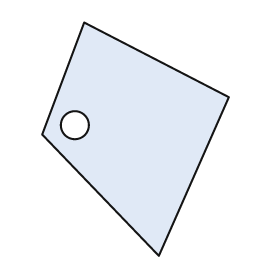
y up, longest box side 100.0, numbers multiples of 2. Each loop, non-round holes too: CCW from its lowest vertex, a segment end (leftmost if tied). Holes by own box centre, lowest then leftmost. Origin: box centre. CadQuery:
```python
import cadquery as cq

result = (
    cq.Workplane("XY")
    .moveTo(10.0, -50.0)
    .lineTo(40.0, 18.0)
    .lineTo(-22.0, 50.0)
    .lineTo(-40.0, 2.0)
    .close()
    .moveTo(-26.0, 6.0)
    .circle(6.0)
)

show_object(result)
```